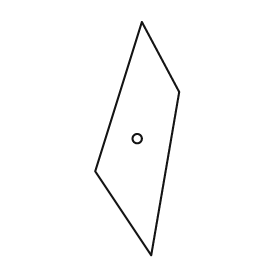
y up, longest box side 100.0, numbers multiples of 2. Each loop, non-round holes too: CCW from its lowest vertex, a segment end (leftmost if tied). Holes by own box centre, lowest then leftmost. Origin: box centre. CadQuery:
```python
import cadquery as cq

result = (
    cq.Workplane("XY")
    .moveTo(6.0, -50.0)
    .lineTo(18.0, 20.0)
    .lineTo(2.0, 50.0)
    .lineTo(-18.0, -14.0)
    .close()
    .moveTo(0.0, 0.0)
    .circle(2.0)
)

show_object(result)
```